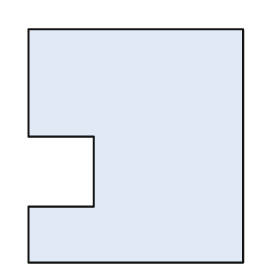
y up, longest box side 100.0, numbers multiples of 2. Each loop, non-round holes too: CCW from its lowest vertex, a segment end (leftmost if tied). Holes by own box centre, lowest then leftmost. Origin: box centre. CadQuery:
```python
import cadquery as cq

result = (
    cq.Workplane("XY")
    .moveTo(-46.0, -50.0)
    .lineTo(46.0, -50.0)
    .lineTo(46.0, 50.0)
    .lineTo(-46.0, 50.0)
    .lineTo(-46.0, 4.0)
    .lineTo(-18.0, 4.0)
    .lineTo(-18.0, -26.0)
    .lineTo(-46.0, -26.0)
    .close()
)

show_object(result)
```